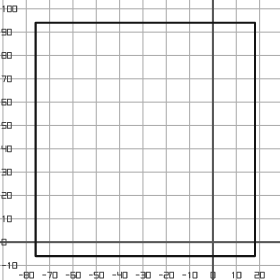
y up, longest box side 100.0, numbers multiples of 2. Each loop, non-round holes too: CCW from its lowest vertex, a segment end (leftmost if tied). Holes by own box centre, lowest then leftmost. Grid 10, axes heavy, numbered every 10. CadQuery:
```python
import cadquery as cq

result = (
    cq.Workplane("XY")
    .moveTo(-76.0, -6.0)
    .lineTo(18.0, -6.0)
    .lineTo(18.0, 94.0)
    .lineTo(-76.0, 94.0)
    .close()
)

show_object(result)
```